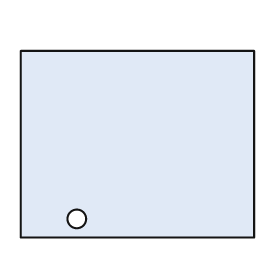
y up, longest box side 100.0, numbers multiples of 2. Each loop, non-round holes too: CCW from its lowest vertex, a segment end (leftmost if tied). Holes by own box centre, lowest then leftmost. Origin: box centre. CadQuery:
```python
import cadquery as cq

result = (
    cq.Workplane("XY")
    .moveTo(-50.0, -40.0)
    .lineTo(50.0, -40.0)
    .lineTo(50.0, 40.0)
    .lineTo(-50.0, 40.0)
    .close()
    .moveTo(-26.0, -32.0)
    .circle(4.0)
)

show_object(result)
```